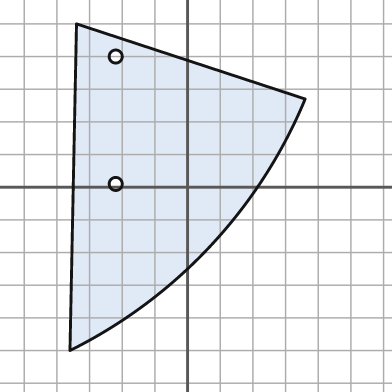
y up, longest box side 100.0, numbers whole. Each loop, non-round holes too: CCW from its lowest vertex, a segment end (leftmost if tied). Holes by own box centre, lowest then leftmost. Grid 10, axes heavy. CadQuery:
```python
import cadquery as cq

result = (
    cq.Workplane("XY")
    .moveTo(-36.0, -50.0)
    .threePointArc((7.0, -18.0), (36.0, 27.0))
    .lineTo(-34.0, 50.0)
    .close()
    .moveTo(-22.0, 1.0)
    .circle(2.0)
    .moveTo(-22.0, 40.0)
    .circle(2.0)
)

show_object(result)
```